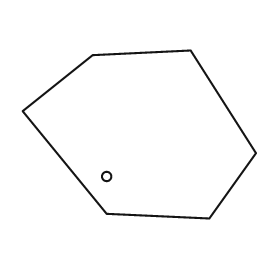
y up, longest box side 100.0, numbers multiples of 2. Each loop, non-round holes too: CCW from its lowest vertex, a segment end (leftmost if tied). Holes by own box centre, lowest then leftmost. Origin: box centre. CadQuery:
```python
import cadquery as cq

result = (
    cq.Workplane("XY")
    .moveTo(30.0, -36.0)
    .lineTo(50.0, -8.0)
    .lineTo(22.0, 36.0)
    .lineTo(-20.0, 34.0)
    .lineTo(-50.0, 10.0)
    .lineTo(-14.0, -34.0)
    .close()
    .moveTo(-14.0, -18.0)
    .circle(2.0)
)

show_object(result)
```